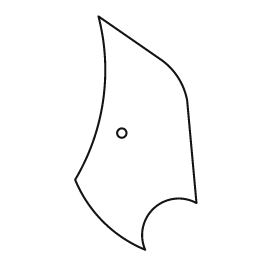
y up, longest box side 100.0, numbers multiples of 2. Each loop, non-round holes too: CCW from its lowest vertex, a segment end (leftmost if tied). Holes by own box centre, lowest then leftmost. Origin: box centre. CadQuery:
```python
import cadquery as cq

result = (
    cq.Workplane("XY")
    .moveTo(4.0, -50.0)
    .threePointArc((8.0, -32.0), (26.0, -30.0))
    .lineTo(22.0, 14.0)
    .threePointArc((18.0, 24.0), (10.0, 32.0))
    .lineTo(-16.0, 50.0)
    .threePointArc((-14.0, 14.0), (-26.0, -20.0))
    .threePointArc((-14.0, -38.0), (4.0, -50.0))
    .close()
    .moveTo(-6.0, 0.0)
    .circle(2.0)
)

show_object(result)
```